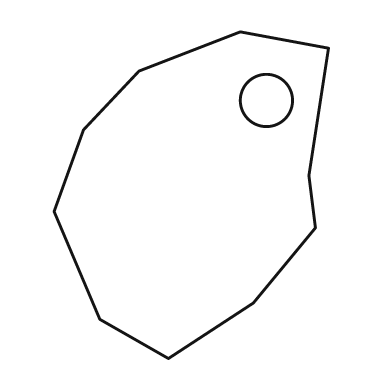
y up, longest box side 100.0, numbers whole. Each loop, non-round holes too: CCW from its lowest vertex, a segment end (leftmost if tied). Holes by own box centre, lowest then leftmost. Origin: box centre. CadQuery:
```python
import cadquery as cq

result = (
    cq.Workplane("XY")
    .moveTo(-7.0, -50.0)
    .lineTo(19.0, -33.0)
    .lineTo(38.0, -10.0)
    .lineTo(36.0, 6.0)
    .lineTo(42.0, 45.0)
    .lineTo(15.0, 50.0)
    .lineTo(-16.0, 38.0)
    .lineTo(-33.0, 20.0)
    .lineTo(-42.0, -5.0)
    .lineTo(-28.0, -38.0)
    .close()
    .moveTo(23.0, 29.0)
    .circle(8.0)
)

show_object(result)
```